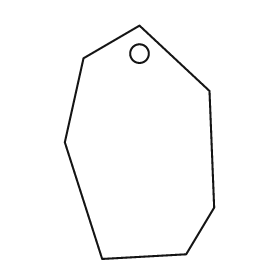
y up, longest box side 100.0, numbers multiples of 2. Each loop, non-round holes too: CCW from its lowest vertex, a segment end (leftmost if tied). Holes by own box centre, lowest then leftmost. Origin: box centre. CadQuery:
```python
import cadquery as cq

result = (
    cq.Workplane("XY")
    .moveTo(-16.0, -50.0)
    .lineTo(20.0, -48.0)
    .lineTo(32.0, -28.0)
    .lineTo(30.0, 22.0)
    .lineTo(0.0, 50.0)
    .lineTo(-24.0, 36.0)
    .lineTo(-32.0, 0.0)
    .close()
    .moveTo(0.0, 38.0)
    .circle(4.0)
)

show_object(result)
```